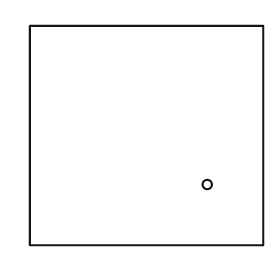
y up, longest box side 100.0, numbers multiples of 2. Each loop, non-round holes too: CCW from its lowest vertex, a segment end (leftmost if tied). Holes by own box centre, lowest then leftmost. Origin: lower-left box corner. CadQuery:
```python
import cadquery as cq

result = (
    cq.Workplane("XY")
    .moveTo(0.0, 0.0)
    .lineTo(100.0, 0.0)
    .lineTo(100.0, 94.0)
    .lineTo(0.0, 94.0)
    .close()
    .moveTo(76.0, 26.0)
    .circle(2.0)
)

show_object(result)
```